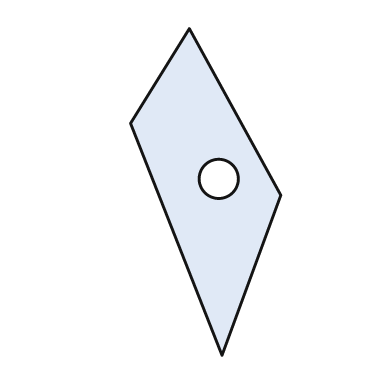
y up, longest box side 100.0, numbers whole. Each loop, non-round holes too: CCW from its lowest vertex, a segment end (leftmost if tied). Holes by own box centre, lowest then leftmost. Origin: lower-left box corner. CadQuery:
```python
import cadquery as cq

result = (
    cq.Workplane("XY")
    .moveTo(28.0, 0.0)
    .lineTo(46.0, 49.0)
    .lineTo(18.0, 100.0)
    .lineTo(0.0, 71.0)
    .close()
    .moveTo(27.0, 54.0)
    .circle(6.0)
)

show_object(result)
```